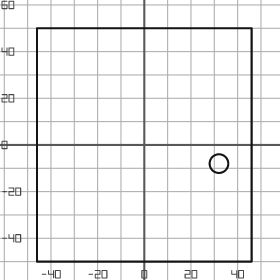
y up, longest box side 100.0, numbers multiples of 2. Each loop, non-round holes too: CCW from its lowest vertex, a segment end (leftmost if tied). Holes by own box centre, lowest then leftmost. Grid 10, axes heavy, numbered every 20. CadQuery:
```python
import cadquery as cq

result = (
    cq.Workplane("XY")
    .moveTo(-46.0, -50.0)
    .lineTo(46.0, -50.0)
    .lineTo(46.0, 50.0)
    .lineTo(-46.0, 50.0)
    .close()
    .moveTo(32.0, -8.0)
    .circle(4.0)
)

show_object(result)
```